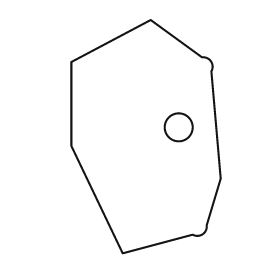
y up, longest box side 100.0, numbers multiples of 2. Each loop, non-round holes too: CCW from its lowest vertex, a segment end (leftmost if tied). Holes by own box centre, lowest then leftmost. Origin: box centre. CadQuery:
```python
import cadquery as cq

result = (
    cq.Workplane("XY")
    .moveTo(-10.0, -50.0)
    .lineTo(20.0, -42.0)
    .threePointArc((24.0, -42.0), (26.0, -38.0))
    .lineTo(32.0, -18.0)
    .lineTo(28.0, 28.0)
    .threePointArc((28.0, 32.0), (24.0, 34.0))
    .lineTo(2.0, 50.0)
    .lineTo(-32.0, 32.0)
    .lineTo(-32.0, -4.0)
    .close()
    .moveTo(14.0, 4.0)
    .circle(6.0)
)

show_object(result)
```